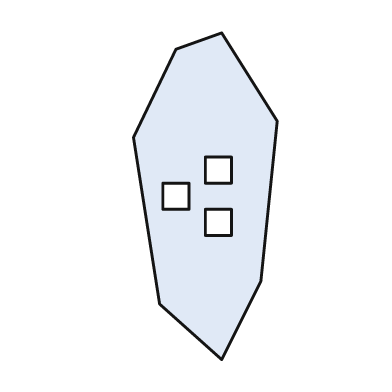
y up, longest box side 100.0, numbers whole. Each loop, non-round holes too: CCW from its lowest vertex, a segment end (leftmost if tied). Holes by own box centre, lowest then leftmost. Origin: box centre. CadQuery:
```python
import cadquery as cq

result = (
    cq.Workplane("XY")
    .moveTo(5.0, -50.0)
    .lineTo(17.0, -26.0)
    .lineTo(22.0, 23.0)
    .lineTo(5.0, 50.0)
    .lineTo(-9.0, 45.0)
    .lineTo(-22.0, 18.0)
    .lineTo(-14.0, -33.0)
    .close()
    .moveTo(0.0, -12.0)
    .lineTo(8.0, -12.0)
    .lineTo(8.0, -4.0)
    .lineTo(0.0, -4.0)
    .close()
    .moveTo(-13.0, -4.0)
    .lineTo(-5.0, -4.0)
    .lineTo(-5.0, 4.0)
    .lineTo(-13.0, 4.0)
    .close()
    .moveTo(0.0, 4.0)
    .lineTo(8.0, 4.0)
    .lineTo(8.0, 12.0)
    .lineTo(0.0, 12.0)
    .close()
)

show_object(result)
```